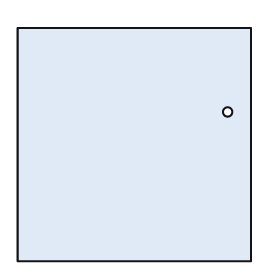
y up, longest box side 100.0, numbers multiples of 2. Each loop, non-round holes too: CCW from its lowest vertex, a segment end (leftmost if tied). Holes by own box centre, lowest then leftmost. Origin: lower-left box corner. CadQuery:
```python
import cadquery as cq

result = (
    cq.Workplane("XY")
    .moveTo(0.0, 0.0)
    .lineTo(100.0, 0.0)
    .lineTo(100.0, 100.0)
    .lineTo(0.0, 100.0)
    .close()
    .moveTo(90.0, 64.0)
    .circle(2.0)
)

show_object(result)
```